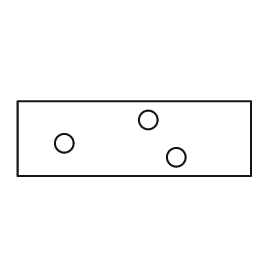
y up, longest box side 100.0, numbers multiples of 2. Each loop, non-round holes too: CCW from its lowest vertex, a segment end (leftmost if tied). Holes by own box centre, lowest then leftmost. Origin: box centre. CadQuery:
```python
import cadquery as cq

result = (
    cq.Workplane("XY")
    .moveTo(-50.0, -16.0)
    .lineTo(50.0, -16.0)
    .lineTo(50.0, 16.0)
    .lineTo(-50.0, 16.0)
    .close()
    .moveTo(18.0, -8.0)
    .circle(4.0)
    .moveTo(-30.0, -2.0)
    .circle(4.0)
    .moveTo(6.0, 8.0)
    .circle(4.0)
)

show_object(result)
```